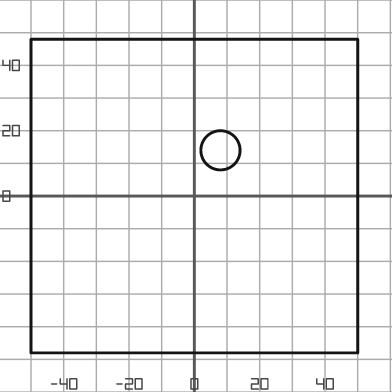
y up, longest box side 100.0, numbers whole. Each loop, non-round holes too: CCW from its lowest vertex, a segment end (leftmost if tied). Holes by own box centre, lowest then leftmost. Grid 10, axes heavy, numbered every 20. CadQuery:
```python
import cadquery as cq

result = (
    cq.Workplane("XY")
    .moveTo(-50.0, -48.0)
    .lineTo(50.0, -48.0)
    .lineTo(50.0, 48.0)
    .lineTo(-50.0, 48.0)
    .close()
    .moveTo(8.0, 14.0)
    .circle(6.0)
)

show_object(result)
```